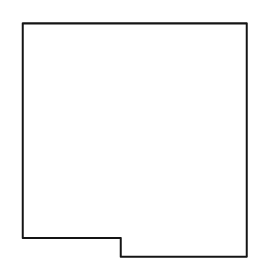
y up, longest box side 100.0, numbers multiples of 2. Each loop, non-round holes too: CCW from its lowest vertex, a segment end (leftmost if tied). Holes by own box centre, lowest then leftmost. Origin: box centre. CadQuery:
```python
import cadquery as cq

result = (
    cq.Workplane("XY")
    .moveTo(-6.0, -50.0)
    .lineTo(48.0, -50.0)
    .lineTo(48.0, 50.0)
    .lineTo(-48.0, 50.0)
    .lineTo(-48.0, -42.0)
    .lineTo(-6.0, -42.0)
    .close()
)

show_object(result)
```